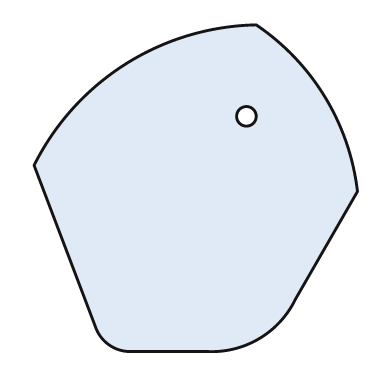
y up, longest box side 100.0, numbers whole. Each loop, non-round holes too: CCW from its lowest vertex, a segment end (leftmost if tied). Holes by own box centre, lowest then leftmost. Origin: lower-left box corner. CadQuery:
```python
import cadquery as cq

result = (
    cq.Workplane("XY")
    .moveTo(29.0, 0.0)
    .lineTo(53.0, 0.0)
    .threePointArc((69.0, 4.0), (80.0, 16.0))
    .lineTo(99.0, 49.0)
    .threePointArc((89.0, 78.0), (68.0, 100.0))
    .threePointArc((28.0, 88.0), (0.0, 57.0))
    .lineTo(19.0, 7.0)
    .threePointArc((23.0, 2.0), (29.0, 0.0))
    .close()
    .moveTo(65.0, 72.0)
    .circle(3.0)
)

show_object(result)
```